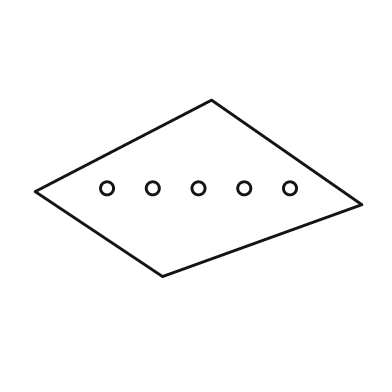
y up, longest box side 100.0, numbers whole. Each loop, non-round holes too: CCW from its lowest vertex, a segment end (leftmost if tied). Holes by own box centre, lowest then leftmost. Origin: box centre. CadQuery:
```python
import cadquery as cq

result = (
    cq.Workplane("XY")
    .moveTo(-11.0, -27.0)
    .lineTo(50.0, -5.0)
    .lineTo(4.0, 27.0)
    .lineTo(-50.0, -1.0)
    .close()
    .moveTo(-28.0, 0.0)
    .circle(2.0)
    .moveTo(-14.0, 0.0)
    .circle(2.0)
    .moveTo(0.0, 0.0)
    .circle(2.0)
    .moveTo(14.0, 0.0)
    .circle(2.0)
    .moveTo(28.0, 0.0)
    .circle(2.0)
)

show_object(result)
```